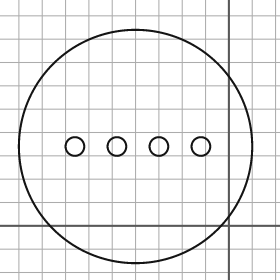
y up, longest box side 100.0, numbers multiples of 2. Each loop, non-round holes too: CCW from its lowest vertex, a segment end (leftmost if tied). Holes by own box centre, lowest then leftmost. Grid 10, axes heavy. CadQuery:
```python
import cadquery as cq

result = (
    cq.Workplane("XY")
    .moveTo(-40.0, 34.0)
    .circle(50.0)
    .moveTo(-66.0, 34.0)
    .circle(4.0)
    .moveTo(-48.0, 34.0)
    .circle(4.0)
    .moveTo(-30.0, 34.0)
    .circle(4.0)
    .moveTo(-12.0, 34.0)
    .circle(4.0)
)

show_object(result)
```